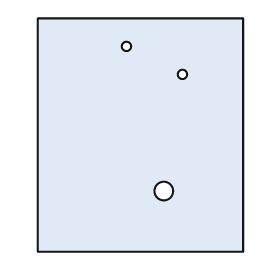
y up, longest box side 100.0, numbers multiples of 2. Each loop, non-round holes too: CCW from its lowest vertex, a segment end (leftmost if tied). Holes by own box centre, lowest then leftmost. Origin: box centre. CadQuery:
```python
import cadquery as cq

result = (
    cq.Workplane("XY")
    .moveTo(-44.0, -50.0)
    .lineTo(44.0, -50.0)
    .lineTo(44.0, 50.0)
    .lineTo(-44.0, 50.0)
    .close()
    .moveTo(10.0, -24.0)
    .circle(4.0)
    .moveTo(18.0, 26.0)
    .circle(2.0)
    .moveTo(-6.0, 38.0)
    .circle(2.0)
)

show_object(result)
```